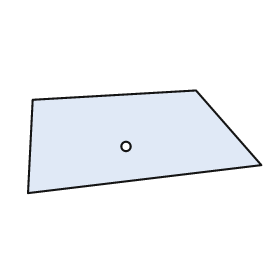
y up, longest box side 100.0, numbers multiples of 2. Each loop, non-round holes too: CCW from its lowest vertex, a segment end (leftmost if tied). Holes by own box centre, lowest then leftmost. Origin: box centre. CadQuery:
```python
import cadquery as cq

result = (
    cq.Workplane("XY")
    .moveTo(-50.0, -22.0)
    .lineTo(50.0, -10.0)
    .lineTo(22.0, 22.0)
    .lineTo(-48.0, 18.0)
    .close()
    .moveTo(-8.0, -2.0)
    .circle(2.0)
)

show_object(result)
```